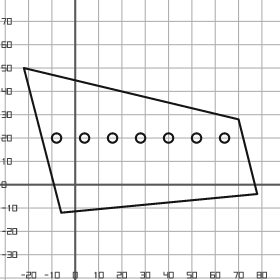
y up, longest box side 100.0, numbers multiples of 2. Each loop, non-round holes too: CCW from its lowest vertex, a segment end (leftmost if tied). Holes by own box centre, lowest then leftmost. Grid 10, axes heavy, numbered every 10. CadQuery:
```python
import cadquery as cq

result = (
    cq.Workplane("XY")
    .moveTo(-6.0, -12.0)
    .lineTo(78.0, -4.0)
    .lineTo(70.0, 28.0)
    .lineTo(-22.0, 50.0)
    .close()
    .moveTo(-8.0, 20.0)
    .circle(2.0)
    .moveTo(4.0, 20.0)
    .circle(2.0)
    .moveTo(16.0, 20.0)
    .circle(2.0)
    .moveTo(28.0, 20.0)
    .circle(2.0)
    .moveTo(40.0, 20.0)
    .circle(2.0)
    .moveTo(52.0, 20.0)
    .circle(2.0)
    .moveTo(64.0, 20.0)
    .circle(2.0)
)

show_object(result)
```